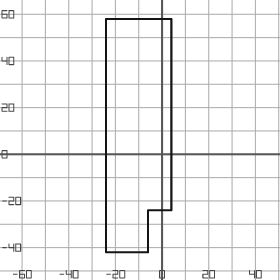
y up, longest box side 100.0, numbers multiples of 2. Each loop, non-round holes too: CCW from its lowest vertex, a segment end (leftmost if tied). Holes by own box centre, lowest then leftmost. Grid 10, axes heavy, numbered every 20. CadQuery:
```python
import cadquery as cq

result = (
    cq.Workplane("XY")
    .moveTo(-24.0, -42.0)
    .lineTo(-6.0, -42.0)
    .lineTo(-6.0, -24.0)
    .lineTo(4.0, -24.0)
    .lineTo(4.0, 58.0)
    .lineTo(-24.0, 58.0)
    .close()
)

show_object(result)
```